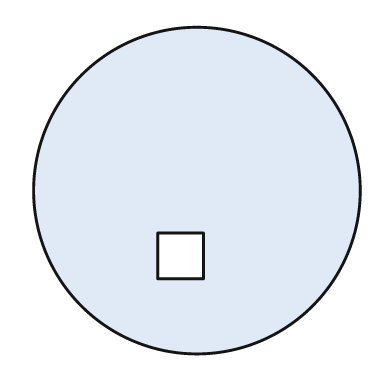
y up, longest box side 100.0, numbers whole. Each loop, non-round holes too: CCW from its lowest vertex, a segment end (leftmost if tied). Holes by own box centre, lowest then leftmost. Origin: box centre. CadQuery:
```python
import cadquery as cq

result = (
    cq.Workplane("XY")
    .moveTo(0.0, 0.0)
    .circle(50.0)
    .moveTo(-12.0, -27.0)
    .lineTo(2.0, -27.0)
    .lineTo(2.0, -13.0)
    .lineTo(-12.0, -13.0)
    .close()
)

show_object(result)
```